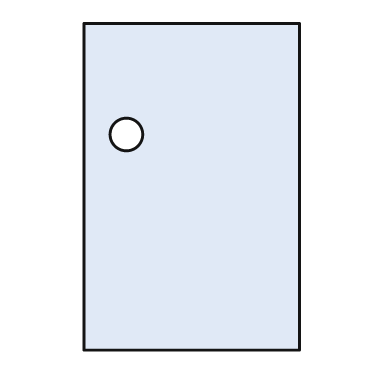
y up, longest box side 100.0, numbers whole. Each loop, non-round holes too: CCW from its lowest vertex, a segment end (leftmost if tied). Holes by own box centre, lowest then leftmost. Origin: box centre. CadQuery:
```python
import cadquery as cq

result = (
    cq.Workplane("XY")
    .moveTo(-33.0, -50.0)
    .lineTo(33.0, -50.0)
    .lineTo(33.0, 50.0)
    .lineTo(-33.0, 50.0)
    .close()
    .moveTo(-20.0, 16.0)
    .circle(5.0)
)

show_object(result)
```